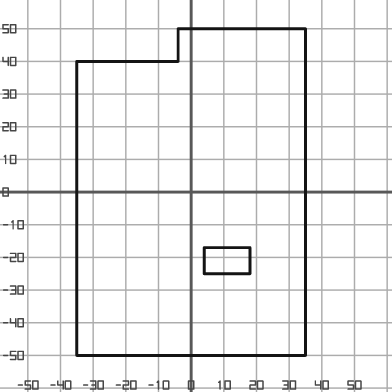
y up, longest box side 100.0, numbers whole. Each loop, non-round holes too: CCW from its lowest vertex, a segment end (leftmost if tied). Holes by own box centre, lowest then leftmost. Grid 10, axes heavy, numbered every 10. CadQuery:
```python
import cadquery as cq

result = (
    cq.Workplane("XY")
    .moveTo(-35.0, -50.0)
    .lineTo(35.0, -50.0)
    .lineTo(35.0, 50.0)
    .lineTo(-4.0, 50.0)
    .lineTo(-4.0, 40.0)
    .lineTo(-35.0, 40.0)
    .close()
    .moveTo(4.0, -25.0)
    .lineTo(18.0, -25.0)
    .lineTo(18.0, -17.0)
    .lineTo(4.0, -17.0)
    .close()
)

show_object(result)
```